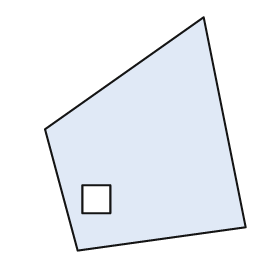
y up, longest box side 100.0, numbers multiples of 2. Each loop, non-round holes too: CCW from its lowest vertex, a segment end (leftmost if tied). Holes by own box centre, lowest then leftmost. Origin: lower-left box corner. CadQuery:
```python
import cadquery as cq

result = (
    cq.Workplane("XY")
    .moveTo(14.0, 0.0)
    .lineTo(86.0, 10.0)
    .lineTo(68.0, 100.0)
    .lineTo(0.0, 52.0)
    .close()
    .moveTo(16.0, 16.0)
    .lineTo(28.0, 16.0)
    .lineTo(28.0, 28.0)
    .lineTo(16.0, 28.0)
    .close()
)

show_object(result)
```